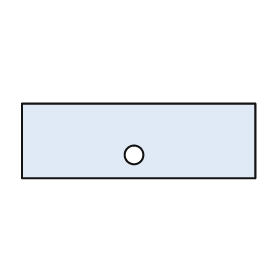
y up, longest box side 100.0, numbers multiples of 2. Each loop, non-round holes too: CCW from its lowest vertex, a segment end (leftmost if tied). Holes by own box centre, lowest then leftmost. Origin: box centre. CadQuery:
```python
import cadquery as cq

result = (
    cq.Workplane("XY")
    .moveTo(-50.0, -16.0)
    .lineTo(50.0, -16.0)
    .lineTo(50.0, 16.0)
    .lineTo(-50.0, 16.0)
    .close()
    .moveTo(-2.0, -6.0)
    .circle(4.0)
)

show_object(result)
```